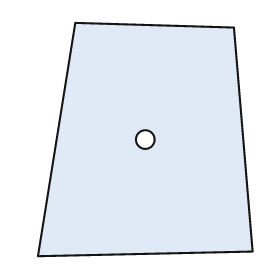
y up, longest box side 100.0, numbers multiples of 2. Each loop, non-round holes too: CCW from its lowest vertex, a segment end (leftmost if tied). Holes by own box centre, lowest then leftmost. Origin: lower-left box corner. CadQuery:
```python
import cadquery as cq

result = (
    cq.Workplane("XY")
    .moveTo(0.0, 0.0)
    .lineTo(92.0, 2.0)
    .lineTo(84.0, 98.0)
    .lineTo(16.0, 100.0)
    .close()
    .moveTo(46.0, 50.0)
    .circle(4.0)
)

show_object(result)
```